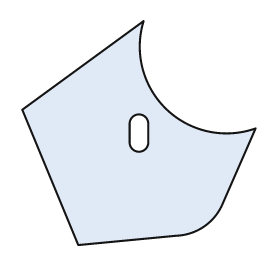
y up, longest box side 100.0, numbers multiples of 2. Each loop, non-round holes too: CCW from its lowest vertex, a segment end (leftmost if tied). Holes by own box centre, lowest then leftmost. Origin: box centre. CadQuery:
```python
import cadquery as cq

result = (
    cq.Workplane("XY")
    .moveTo(-26.0, -48.0)
    .lineTo(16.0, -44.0)
    .threePointArc((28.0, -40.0), (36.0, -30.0))
    .lineTo(50.0, 2.0)
    .threePointArc((12.0, 10.0), (2.0, 48.0))
    .lineTo(-50.0, 10.0)
    .close()
    .moveTo(-4.0, -4.0)
    .threePointArc((0.0, -8.0), (4.0, -4.0))
    .lineTo(4.0, 4.0)
    .threePointArc((0.0, 8.0), (-4.0, 4.0))
    .close()
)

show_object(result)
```